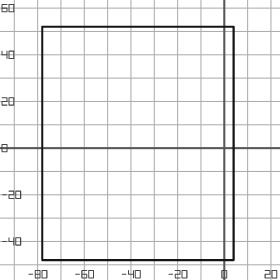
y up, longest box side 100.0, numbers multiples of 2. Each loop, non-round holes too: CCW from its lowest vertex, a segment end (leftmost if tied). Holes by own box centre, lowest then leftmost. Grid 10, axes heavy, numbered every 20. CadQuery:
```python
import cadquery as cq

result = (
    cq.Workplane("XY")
    .moveTo(-78.0, -48.0)
    .lineTo(4.0, -48.0)
    .lineTo(4.0, 52.0)
    .lineTo(-78.0, 52.0)
    .close()
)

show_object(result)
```